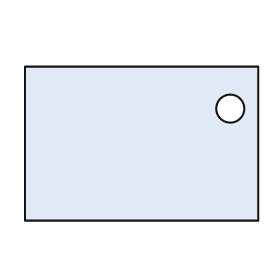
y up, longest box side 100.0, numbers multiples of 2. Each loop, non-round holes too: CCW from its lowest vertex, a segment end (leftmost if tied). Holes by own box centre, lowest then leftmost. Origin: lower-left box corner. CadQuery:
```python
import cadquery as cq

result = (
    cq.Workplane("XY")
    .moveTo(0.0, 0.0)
    .lineTo(100.0, 0.0)
    .lineTo(100.0, 66.0)
    .lineTo(0.0, 66.0)
    .close()
    .moveTo(88.0, 48.0)
    .circle(6.0)
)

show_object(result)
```